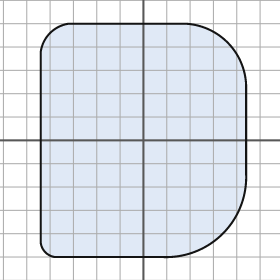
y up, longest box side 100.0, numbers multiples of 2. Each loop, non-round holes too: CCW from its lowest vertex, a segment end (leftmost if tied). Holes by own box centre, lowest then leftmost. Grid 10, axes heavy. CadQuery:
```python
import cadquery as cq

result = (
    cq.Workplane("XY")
    .moveTo(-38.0, -50.0)
    .lineTo(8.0, -50.0)
    .threePointArc((34.0, -40.0), (44.0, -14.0))
    .lineTo(44.0, 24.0)
    .threePointArc((36.0, 42.0), (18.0, 50.0))
    .lineTo(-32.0, 50.0)
    .threePointArc((-40.0, 46.0), (-44.0, 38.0))
    .lineTo(-44.0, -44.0)
    .threePointArc((-42.0, -48.0), (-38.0, -50.0))
    .close()
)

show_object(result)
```